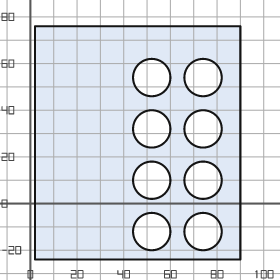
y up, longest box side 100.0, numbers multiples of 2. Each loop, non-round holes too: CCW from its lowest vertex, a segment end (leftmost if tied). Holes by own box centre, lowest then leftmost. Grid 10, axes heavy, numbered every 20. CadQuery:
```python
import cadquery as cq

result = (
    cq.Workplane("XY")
    .moveTo(2.0, -24.0)
    .lineTo(90.0, -24.0)
    .lineTo(90.0, 76.0)
    .lineTo(2.0, 76.0)
    .close()
    .moveTo(52.0, -12.0)
    .circle(8.0)
    .moveTo(74.0, -12.0)
    .circle(8.0)
    .moveTo(52.0, 10.0)
    .circle(8.0)
    .moveTo(74.0, 10.0)
    .circle(8.0)
    .moveTo(52.0, 32.0)
    .circle(8.0)
    .moveTo(74.0, 32.0)
    .circle(8.0)
    .moveTo(52.0, 54.0)
    .circle(8.0)
    .moveTo(74.0, 54.0)
    .circle(8.0)
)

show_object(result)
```